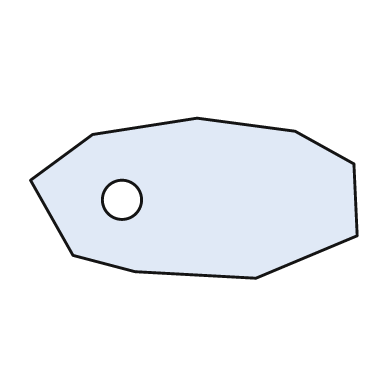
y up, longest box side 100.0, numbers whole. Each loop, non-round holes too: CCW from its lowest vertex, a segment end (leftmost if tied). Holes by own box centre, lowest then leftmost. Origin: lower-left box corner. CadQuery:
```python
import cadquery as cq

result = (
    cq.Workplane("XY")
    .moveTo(69.0, 0.0)
    .lineTo(100.0, 13.0)
    .lineTo(99.0, 35.0)
    .lineTo(81.0, 45.0)
    .lineTo(51.0, 49.0)
    .lineTo(19.0, 44.0)
    .lineTo(0.0, 30.0)
    .lineTo(13.0, 7.0)
    .lineTo(32.0, 2.0)
    .close()
    .moveTo(28.0, 24.0)
    .circle(6.0)
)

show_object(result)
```